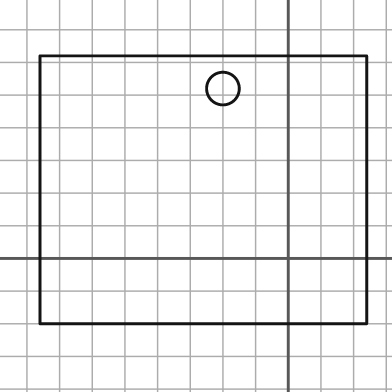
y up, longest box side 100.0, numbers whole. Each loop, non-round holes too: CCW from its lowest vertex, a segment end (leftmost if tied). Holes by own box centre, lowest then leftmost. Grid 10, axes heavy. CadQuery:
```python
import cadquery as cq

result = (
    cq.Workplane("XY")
    .moveTo(-76.0, -20.0)
    .lineTo(24.0, -20.0)
    .lineTo(24.0, 62.0)
    .lineTo(-76.0, 62.0)
    .close()
    .moveTo(-20.0, 52.0)
    .circle(5.0)
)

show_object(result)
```